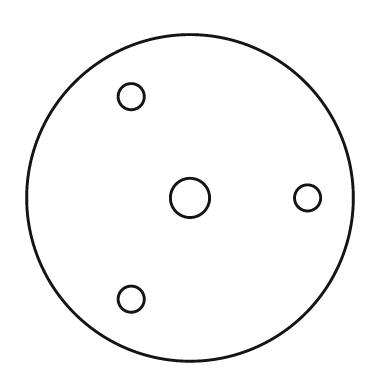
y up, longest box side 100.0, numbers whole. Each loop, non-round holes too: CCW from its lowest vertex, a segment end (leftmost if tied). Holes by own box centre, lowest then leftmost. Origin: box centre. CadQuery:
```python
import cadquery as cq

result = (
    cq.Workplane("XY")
    .moveTo(0.0, 0.0)
    .circle(50.0)
    .moveTo(-18.0, -31.0)
    .circle(4.0)
    .moveTo(0.0, 0.0)
    .circle(6.0)
    .moveTo(36.0, 0.0)
    .circle(4.0)
    .moveTo(-18.0, 31.0)
    .circle(4.0)
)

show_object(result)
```